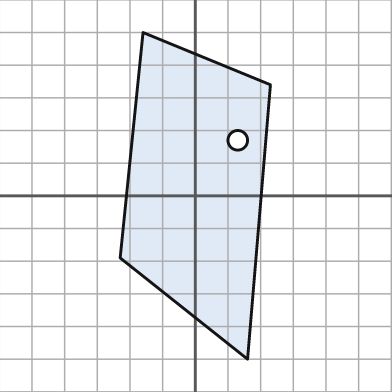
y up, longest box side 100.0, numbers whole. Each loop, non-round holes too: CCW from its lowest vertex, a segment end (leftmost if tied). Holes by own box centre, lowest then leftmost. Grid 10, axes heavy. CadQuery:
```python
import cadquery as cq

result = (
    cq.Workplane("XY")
    .moveTo(16.0, -50.0)
    .lineTo(23.0, 34.0)
    .lineTo(-16.0, 50.0)
    .lineTo(-23.0, -19.0)
    .close()
    .moveTo(13.0, 17.0)
    .circle(3.0)
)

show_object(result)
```